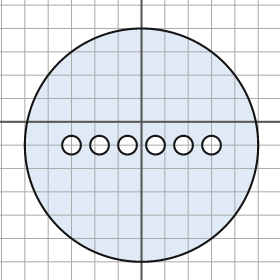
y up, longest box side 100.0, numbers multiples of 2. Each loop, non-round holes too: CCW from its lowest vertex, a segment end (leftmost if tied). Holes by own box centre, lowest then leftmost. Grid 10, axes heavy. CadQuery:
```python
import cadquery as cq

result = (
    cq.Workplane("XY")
    .moveTo(0.0, -10.0)
    .circle(50.0)
    .moveTo(-30.0, -10.0)
    .circle(4.0)
    .moveTo(-18.0, -10.0)
    .circle(4.0)
    .moveTo(-6.0, -10.0)
    .circle(4.0)
    .moveTo(6.0, -10.0)
    .circle(4.0)
    .moveTo(18.0, -10.0)
    .circle(4.0)
    .moveTo(30.0, -10.0)
    .circle(4.0)
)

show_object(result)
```